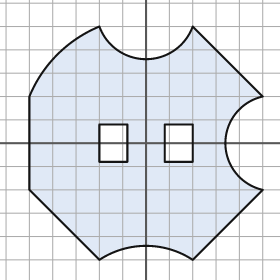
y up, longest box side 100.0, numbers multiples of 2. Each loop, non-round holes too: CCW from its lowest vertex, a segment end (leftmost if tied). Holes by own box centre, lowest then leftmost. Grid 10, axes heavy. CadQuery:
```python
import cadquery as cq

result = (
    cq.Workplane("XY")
    .moveTo(-20.0, -50.0)
    .threePointArc((0.0, -44.0), (20.0, -50.0))
    .lineTo(50.0, -20.0)
    .threePointArc((34.0, 0.0), (50.0, 20.0))
    .lineTo(20.0, 50.0)
    .threePointArc((0.0, 36.0), (-20.0, 50.0))
    .threePointArc((-38.0, 38.0), (-50.0, 20.0))
    .lineTo(-50.0, -20.0)
    .close()
    .moveTo(-20.0, -8.0)
    .lineTo(-8.0, -8.0)
    .lineTo(-8.0, 8.0)
    .lineTo(-20.0, 8.0)
    .close()
    .moveTo(8.0, -8.0)
    .lineTo(20.0, -8.0)
    .lineTo(20.0, 8.0)
    .lineTo(8.0, 8.0)
    .close()
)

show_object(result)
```